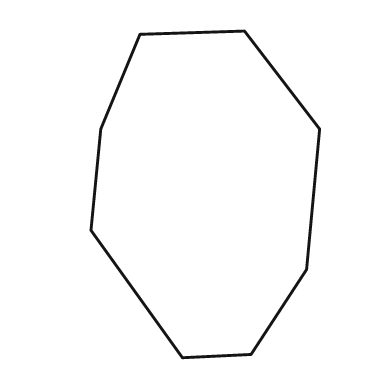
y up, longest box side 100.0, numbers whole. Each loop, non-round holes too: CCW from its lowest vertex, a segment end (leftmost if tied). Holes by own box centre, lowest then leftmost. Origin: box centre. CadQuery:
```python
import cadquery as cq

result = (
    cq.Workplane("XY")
    .moveTo(-7.0, -50.0)
    .lineTo(14.0, -49.0)
    .lineTo(31.0, -23.0)
    .lineTo(35.0, 20.0)
    .lineTo(12.0, 50.0)
    .lineTo(-20.0, 49.0)
    .lineTo(-32.0, 20.0)
    .lineTo(-35.0, -11.0)
    .close()
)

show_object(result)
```